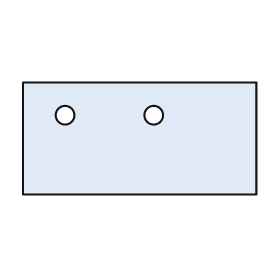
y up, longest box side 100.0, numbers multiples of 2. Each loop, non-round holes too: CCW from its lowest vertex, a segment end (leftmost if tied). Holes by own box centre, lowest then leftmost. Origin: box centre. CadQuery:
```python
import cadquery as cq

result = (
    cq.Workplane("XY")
    .moveTo(-50.0, -24.0)
    .lineTo(50.0, -24.0)
    .lineTo(50.0, 24.0)
    .lineTo(-50.0, 24.0)
    .close()
    .moveTo(-32.0, 10.0)
    .circle(4.0)
    .moveTo(6.0, 10.0)
    .circle(4.0)
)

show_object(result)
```